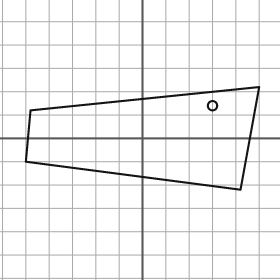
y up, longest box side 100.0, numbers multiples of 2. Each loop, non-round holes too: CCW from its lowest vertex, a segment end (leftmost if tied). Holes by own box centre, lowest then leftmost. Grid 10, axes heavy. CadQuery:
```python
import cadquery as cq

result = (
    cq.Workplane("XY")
    .moveTo(42.0, -22.0)
    .lineTo(50.0, 22.0)
    .lineTo(-48.0, 12.0)
    .lineTo(-50.0, -10.0)
    .close()
    .moveTo(30.0, 14.0)
    .circle(2.0)
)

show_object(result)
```